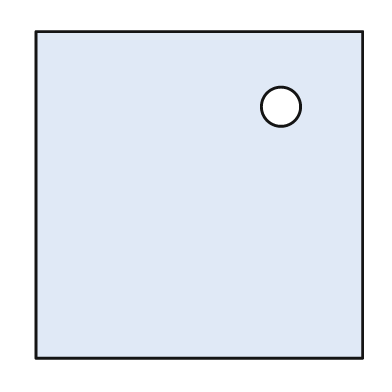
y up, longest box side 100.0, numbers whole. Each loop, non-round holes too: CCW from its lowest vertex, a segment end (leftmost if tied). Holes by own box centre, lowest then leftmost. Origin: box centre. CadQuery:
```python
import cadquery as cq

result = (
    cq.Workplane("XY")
    .moveTo(-50.0, -50.0)
    .lineTo(50.0, -50.0)
    .lineTo(50.0, 50.0)
    .lineTo(-50.0, 50.0)
    .close()
    .moveTo(25.0, 27.0)
    .circle(6.0)
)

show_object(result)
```